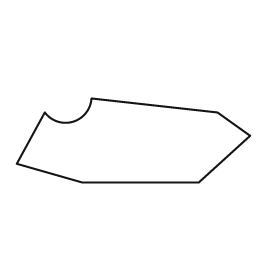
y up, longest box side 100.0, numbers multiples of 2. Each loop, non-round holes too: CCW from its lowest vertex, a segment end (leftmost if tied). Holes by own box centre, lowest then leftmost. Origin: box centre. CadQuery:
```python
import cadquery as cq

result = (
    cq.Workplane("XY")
    .moveTo(-22.0, -18.0)
    .lineTo(28.0, -18.0)
    .lineTo(50.0, 2.0)
    .lineTo(36.0, 12.0)
    .lineTo(-18.0, 18.0)
    .threePointArc((-26.0, 8.0), (-38.0, 12.0))
    .lineTo(-50.0, -10.0)
    .close()
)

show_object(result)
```